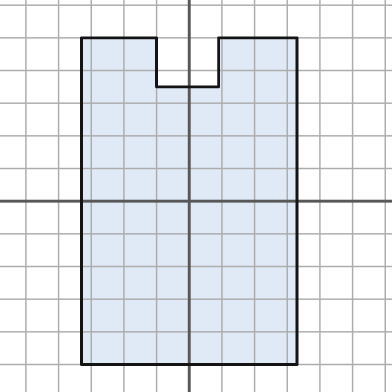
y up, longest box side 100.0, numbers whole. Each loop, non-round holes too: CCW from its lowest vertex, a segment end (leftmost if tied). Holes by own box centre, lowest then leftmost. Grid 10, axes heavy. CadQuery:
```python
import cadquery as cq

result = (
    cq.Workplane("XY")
    .moveTo(-33.0, -50.0)
    .lineTo(33.0, -50.0)
    .lineTo(33.0, 50.0)
    .lineTo(9.0, 50.0)
    .lineTo(9.0, 35.0)
    .lineTo(-10.0, 35.0)
    .lineTo(-10.0, 50.0)
    .lineTo(-33.0, 50.0)
    .close()
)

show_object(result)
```